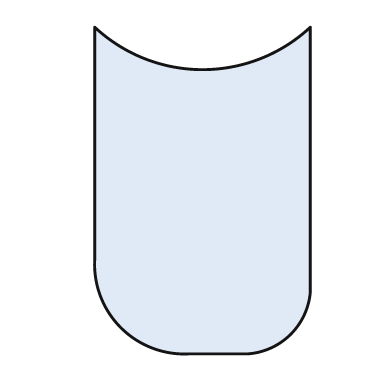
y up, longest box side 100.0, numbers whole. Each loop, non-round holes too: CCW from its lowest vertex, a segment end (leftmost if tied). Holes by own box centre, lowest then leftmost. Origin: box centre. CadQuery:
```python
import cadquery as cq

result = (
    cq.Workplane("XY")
    .moveTo(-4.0, -50.0)
    .lineTo(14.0, -50.0)
    .threePointArc((27.0, -44.0), (33.0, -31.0))
    .lineTo(33.0, 50.0)
    .threePointArc((0.0, 37.0), (-33.0, 50.0))
    .lineTo(-33.0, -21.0)
    .threePointArc((-25.0, -42.0), (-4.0, -50.0))
    .close()
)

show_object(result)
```